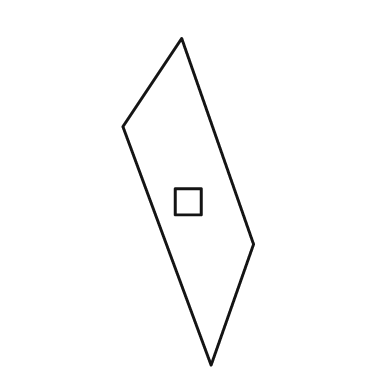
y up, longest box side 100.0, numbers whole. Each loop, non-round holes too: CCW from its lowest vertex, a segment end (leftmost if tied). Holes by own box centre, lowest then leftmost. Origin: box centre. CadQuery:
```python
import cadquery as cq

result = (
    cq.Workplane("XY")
    .moveTo(7.0, -50.0)
    .lineTo(20.0, -13.0)
    .lineTo(-2.0, 50.0)
    .lineTo(-20.0, 23.0)
    .close()
    .moveTo(-4.0, -4.0)
    .lineTo(4.0, -4.0)
    .lineTo(4.0, 4.0)
    .lineTo(-4.0, 4.0)
    .close()
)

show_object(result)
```